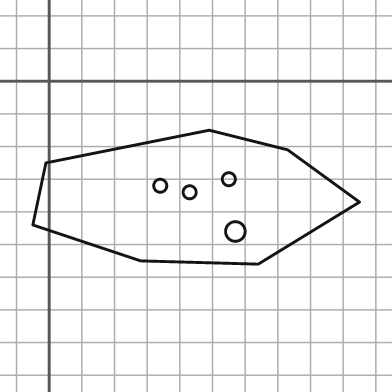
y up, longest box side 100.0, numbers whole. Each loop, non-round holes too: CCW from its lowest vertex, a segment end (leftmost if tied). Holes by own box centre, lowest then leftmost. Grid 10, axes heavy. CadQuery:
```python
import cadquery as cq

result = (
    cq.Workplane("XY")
    .moveTo(64.0, -56.0)
    .lineTo(95.0, -37.0)
    .lineTo(73.0, -21.0)
    .lineTo(49.0, -15.0)
    .lineTo(-1.0, -25.0)
    .lineTo(-5.0, -44.0)
    .lineTo(28.0, -55.0)
    .close()
    .moveTo(57.0, -46.0)
    .circle(3.0)
    .moveTo(43.0, -34.0)
    .circle(2.0)
    .moveTo(34.0, -32.0)
    .circle(2.0)
    .moveTo(55.0, -30.0)
    .circle(2.0)
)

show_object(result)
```